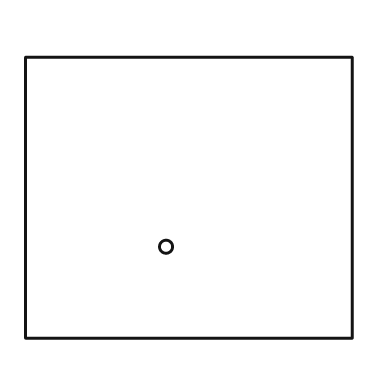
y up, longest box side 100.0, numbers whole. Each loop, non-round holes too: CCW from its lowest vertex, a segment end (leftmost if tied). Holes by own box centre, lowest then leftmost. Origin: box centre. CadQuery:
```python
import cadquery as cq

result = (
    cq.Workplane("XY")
    .moveTo(-50.0, -43.0)
    .lineTo(50.0, -43.0)
    .lineTo(50.0, 43.0)
    .lineTo(-50.0, 43.0)
    .close()
    .moveTo(-7.0, -15.0)
    .circle(2.0)
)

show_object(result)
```